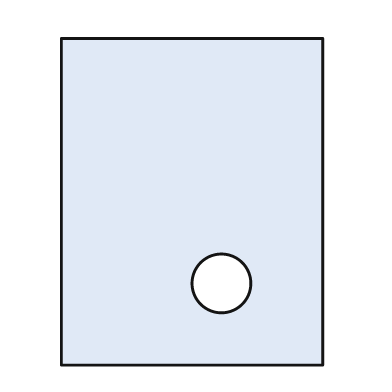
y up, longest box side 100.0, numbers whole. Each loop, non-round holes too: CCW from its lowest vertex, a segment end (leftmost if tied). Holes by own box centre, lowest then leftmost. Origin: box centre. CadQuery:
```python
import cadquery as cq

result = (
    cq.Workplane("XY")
    .moveTo(-40.0, -50.0)
    .lineTo(40.0, -50.0)
    .lineTo(40.0, 50.0)
    .lineTo(-40.0, 50.0)
    .close()
    .moveTo(9.0, -25.0)
    .circle(9.0)
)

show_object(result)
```